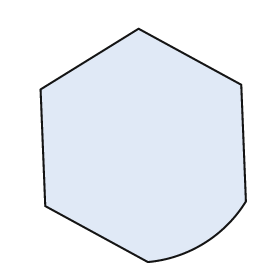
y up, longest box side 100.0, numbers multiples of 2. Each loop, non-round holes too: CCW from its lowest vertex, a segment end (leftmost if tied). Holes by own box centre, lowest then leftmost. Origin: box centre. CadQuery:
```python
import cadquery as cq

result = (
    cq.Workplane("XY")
    .moveTo(2.0, -50.0)
    .threePointArc((26.0, -42.0), (44.0, -24.0))
    .lineTo(42.0, 26.0)
    .lineTo(-2.0, 50.0)
    .lineTo(-44.0, 24.0)
    .lineTo(-42.0, -26.0)
    .close()
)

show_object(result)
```